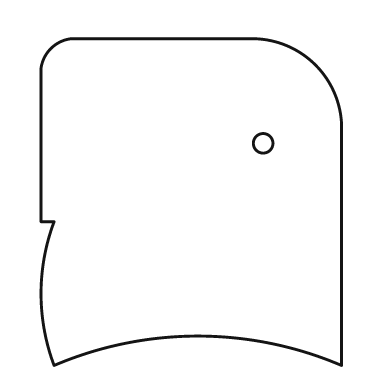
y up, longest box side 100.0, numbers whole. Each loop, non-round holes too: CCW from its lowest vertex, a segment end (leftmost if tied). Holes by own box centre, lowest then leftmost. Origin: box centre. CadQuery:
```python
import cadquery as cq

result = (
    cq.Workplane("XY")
    .moveTo(-42.0, -50.0)
    .threePointArc((2.0, -41.0), (46.0, -50.0))
    .lineTo(46.0, 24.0)
    .threePointArc((38.0, 42.0), (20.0, 50.0))
    .lineTo(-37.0, 50.0)
    .threePointArc((-43.0, 47.0), (-46.0, 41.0))
    .lineTo(-46.0, -6.0)
    .lineTo(-42.0, -6.0)
    .threePointArc((-46.0, -28.0), (-42.0, -50.0))
    .close()
    .moveTo(22.0, 18.0)
    .circle(3.0)
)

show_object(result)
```